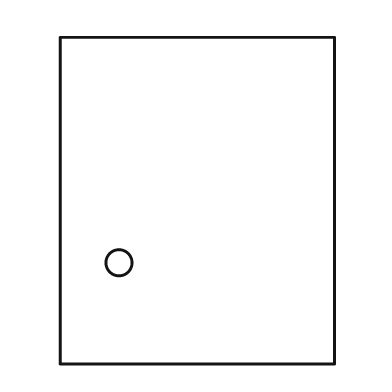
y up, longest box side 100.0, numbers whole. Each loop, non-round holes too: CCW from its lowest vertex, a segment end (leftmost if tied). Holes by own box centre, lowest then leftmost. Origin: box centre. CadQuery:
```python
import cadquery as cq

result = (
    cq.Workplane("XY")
    .moveTo(-42.0, -50.0)
    .lineTo(42.0, -50.0)
    .lineTo(42.0, 50.0)
    .lineTo(-42.0, 50.0)
    .close()
    .moveTo(-24.0, -19.0)
    .circle(4.0)
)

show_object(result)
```